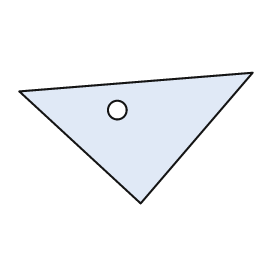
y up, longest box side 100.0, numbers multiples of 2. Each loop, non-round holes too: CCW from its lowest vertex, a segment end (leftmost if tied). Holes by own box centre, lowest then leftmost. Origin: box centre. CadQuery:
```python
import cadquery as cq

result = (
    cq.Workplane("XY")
    .moveTo(2.0, -28.0)
    .lineTo(50.0, 28.0)
    .lineTo(-50.0, 20.0)
    .close()
    .moveTo(-8.0, 12.0)
    .circle(4.0)
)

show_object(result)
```